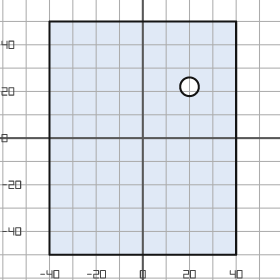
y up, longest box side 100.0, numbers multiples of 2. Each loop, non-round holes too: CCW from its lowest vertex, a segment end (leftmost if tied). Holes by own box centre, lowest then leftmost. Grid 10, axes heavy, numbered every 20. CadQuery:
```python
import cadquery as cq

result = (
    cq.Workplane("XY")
    .moveTo(-40.0, -50.0)
    .lineTo(40.0, -50.0)
    .lineTo(40.0, 50.0)
    .lineTo(-40.0, 50.0)
    .close()
    .moveTo(20.0, 22.0)
    .circle(4.0)
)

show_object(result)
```